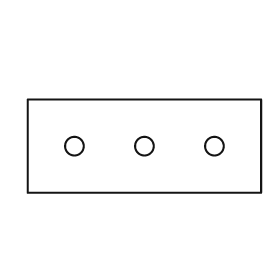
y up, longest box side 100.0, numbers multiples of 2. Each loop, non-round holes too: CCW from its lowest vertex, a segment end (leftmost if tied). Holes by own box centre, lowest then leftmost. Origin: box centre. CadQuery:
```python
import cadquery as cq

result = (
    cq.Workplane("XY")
    .moveTo(-50.0, -20.0)
    .lineTo(50.0, -20.0)
    .lineTo(50.0, 20.0)
    .lineTo(-50.0, 20.0)
    .close()
    .moveTo(-30.0, 0.0)
    .circle(4.0)
    .moveTo(0.0, 0.0)
    .circle(4.0)
    .moveTo(30.0, 0.0)
    .circle(4.0)
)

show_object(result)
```